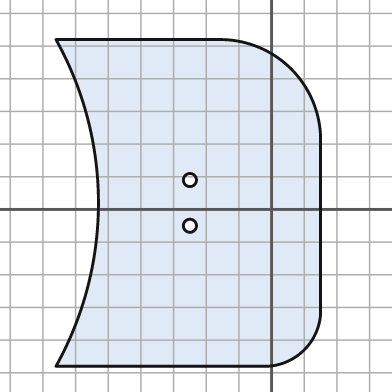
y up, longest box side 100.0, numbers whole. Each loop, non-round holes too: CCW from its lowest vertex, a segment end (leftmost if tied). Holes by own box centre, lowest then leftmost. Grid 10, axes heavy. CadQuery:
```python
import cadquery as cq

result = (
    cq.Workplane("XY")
    .moveTo(-66.0, -48.0)
    .lineTo(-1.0, -48.0)
    .threePointArc((10.0, -43.0), (15.0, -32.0))
    .lineTo(15.0, 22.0)
    .threePointArc((6.0, 43.0), (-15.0, 52.0))
    .lineTo(-66.0, 52.0)
    .threePointArc((-53.0, 2.0), (-66.0, -48.0))
    .close()
    .moveTo(-25.0, -5.0)
    .circle(2.0)
    .moveTo(-25.0, 9.0)
    .circle(2.0)
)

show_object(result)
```